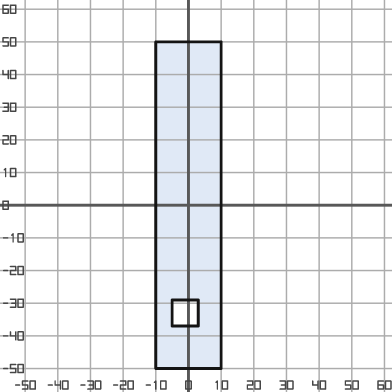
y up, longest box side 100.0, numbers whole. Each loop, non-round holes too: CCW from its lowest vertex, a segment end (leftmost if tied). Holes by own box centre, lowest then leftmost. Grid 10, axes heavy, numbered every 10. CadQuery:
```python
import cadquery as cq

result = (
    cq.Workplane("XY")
    .moveTo(-10.0, -50.0)
    .lineTo(10.0, -50.0)
    .lineTo(10.0, 50.0)
    .lineTo(-10.0, 50.0)
    .close()
    .moveTo(-5.0, -37.0)
    .lineTo(3.0, -37.0)
    .lineTo(3.0, -29.0)
    .lineTo(-5.0, -29.0)
    .close()
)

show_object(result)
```